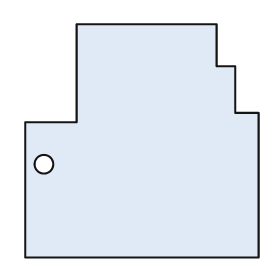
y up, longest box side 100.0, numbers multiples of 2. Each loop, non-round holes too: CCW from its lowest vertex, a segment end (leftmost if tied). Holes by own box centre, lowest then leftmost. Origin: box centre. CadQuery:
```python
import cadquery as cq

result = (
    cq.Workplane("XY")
    .moveTo(-50.0, -50.0)
    .lineTo(50.0, -50.0)
    .lineTo(50.0, 12.0)
    .lineTo(40.0, 12.0)
    .lineTo(40.0, 32.0)
    .lineTo(32.0, 32.0)
    .lineTo(32.0, 50.0)
    .lineTo(-28.0, 50.0)
    .lineTo(-28.0, 8.0)
    .lineTo(-50.0, 8.0)
    .close()
    .moveTo(-42.0, -10.0)
    .circle(4.0)
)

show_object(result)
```